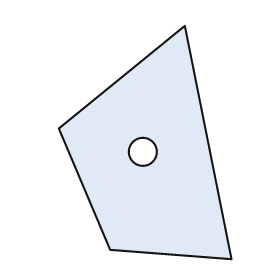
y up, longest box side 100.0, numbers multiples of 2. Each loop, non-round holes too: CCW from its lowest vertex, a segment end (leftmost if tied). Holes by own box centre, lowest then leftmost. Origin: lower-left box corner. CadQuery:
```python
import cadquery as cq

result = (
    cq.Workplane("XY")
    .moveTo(74.0, 0.0)
    .lineTo(54.0, 100.0)
    .lineTo(0.0, 56.0)
    .lineTo(22.0, 4.0)
    .close()
    .moveTo(36.0, 46.0)
    .circle(6.0)
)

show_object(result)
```